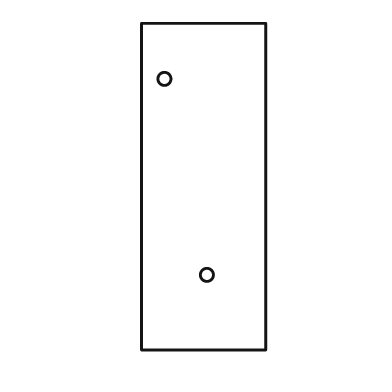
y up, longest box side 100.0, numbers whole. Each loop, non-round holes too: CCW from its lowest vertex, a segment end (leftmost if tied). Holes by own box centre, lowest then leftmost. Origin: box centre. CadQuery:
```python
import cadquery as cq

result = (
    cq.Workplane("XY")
    .moveTo(-19.0, -50.0)
    .lineTo(19.0, -50.0)
    .lineTo(19.0, 50.0)
    .lineTo(-19.0, 50.0)
    .close()
    .moveTo(1.0, -27.0)
    .circle(2.0)
    .moveTo(-12.0, 33.0)
    .circle(2.0)
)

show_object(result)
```